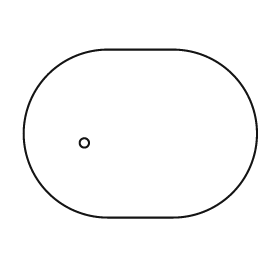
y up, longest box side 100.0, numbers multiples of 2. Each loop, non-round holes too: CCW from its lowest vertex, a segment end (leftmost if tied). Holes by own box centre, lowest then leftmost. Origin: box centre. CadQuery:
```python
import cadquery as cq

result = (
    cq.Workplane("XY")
    .moveTo(-14.0, -36.0)
    .lineTo(14.0, -36.0)
    .threePointArc((50.0, 0.0), (14.0, 36.0))
    .lineTo(-14.0, 36.0)
    .threePointArc((-50.0, 0.0), (-14.0, -36.0))
    .close()
    .moveTo(-24.0, -4.0)
    .circle(2.0)
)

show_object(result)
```